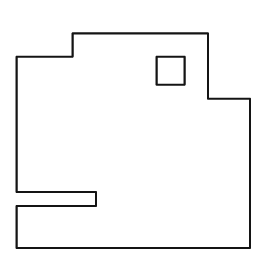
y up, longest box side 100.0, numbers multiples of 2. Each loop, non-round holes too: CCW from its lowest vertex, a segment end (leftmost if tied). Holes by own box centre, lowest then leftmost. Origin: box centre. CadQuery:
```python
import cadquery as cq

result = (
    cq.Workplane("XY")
    .moveTo(-50.0, -46.0)
    .lineTo(50.0, -46.0)
    .lineTo(50.0, 18.0)
    .lineTo(32.0, 18.0)
    .lineTo(32.0, 46.0)
    .lineTo(-26.0, 46.0)
    .lineTo(-26.0, 36.0)
    .lineTo(-50.0, 36.0)
    .lineTo(-50.0, -22.0)
    .lineTo(-16.0, -22.0)
    .lineTo(-16.0, -28.0)
    .lineTo(-50.0, -28.0)
    .close()
    .moveTo(10.0, 24.0)
    .lineTo(22.0, 24.0)
    .lineTo(22.0, 36.0)
    .lineTo(10.0, 36.0)
    .close()
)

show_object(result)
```